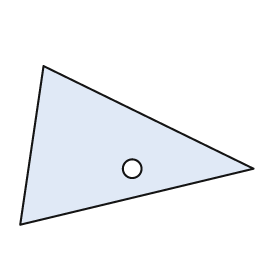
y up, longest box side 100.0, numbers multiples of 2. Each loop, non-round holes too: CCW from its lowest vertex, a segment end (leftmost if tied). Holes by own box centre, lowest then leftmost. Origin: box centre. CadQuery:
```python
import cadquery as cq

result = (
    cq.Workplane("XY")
    .moveTo(-50.0, -34.0)
    .lineTo(50.0, -10.0)
    .lineTo(-40.0, 34.0)
    .close()
    .moveTo(-2.0, -10.0)
    .circle(4.0)
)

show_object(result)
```